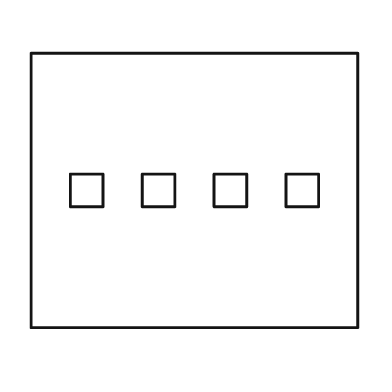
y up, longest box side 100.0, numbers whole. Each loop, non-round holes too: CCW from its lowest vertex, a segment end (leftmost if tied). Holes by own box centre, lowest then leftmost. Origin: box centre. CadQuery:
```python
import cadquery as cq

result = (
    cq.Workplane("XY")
    .moveTo(-50.0, -42.0)
    .lineTo(50.0, -42.0)
    .lineTo(50.0, 42.0)
    .lineTo(-50.0, 42.0)
    .close()
    .moveTo(-38.0, -5.0)
    .lineTo(-28.0, -5.0)
    .lineTo(-28.0, 5.0)
    .lineTo(-38.0, 5.0)
    .close()
    .moveTo(-16.0, -5.0)
    .lineTo(-6.0, -5.0)
    .lineTo(-6.0, 5.0)
    .lineTo(-16.0, 5.0)
    .close()
    .moveTo(6.0, -5.0)
    .lineTo(16.0, -5.0)
    .lineTo(16.0, 5.0)
    .lineTo(6.0, 5.0)
    .close()
    .moveTo(28.0, -5.0)
    .lineTo(38.0, -5.0)
    .lineTo(38.0, 5.0)
    .lineTo(28.0, 5.0)
    .close()
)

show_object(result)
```